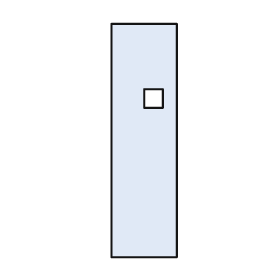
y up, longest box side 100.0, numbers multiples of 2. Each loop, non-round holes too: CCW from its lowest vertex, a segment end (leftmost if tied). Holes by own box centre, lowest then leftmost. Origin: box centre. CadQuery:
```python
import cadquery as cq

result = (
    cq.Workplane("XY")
    .moveTo(-14.0, -50.0)
    .lineTo(14.0, -50.0)
    .lineTo(14.0, 50.0)
    .lineTo(-14.0, 50.0)
    .close()
    .moveTo(0.0, 14.0)
    .lineTo(8.0, 14.0)
    .lineTo(8.0, 22.0)
    .lineTo(0.0, 22.0)
    .close()
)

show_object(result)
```